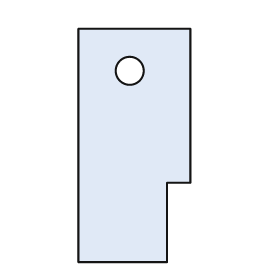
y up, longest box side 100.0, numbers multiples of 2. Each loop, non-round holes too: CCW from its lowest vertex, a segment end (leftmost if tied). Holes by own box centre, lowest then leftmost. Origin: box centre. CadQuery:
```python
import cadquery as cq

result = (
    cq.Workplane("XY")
    .moveTo(-24.0, -50.0)
    .lineTo(14.0, -50.0)
    .lineTo(14.0, -16.0)
    .lineTo(24.0, -16.0)
    .lineTo(24.0, 50.0)
    .lineTo(-24.0, 50.0)
    .close()
    .moveTo(-2.0, 32.0)
    .circle(6.0)
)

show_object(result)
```